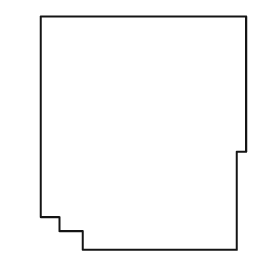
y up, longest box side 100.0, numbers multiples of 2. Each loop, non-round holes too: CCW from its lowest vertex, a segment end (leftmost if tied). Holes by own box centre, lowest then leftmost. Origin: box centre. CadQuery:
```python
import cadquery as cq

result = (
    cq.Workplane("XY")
    .moveTo(-26.0, -50.0)
    .lineTo(40.0, -50.0)
    .lineTo(40.0, -8.0)
    .lineTo(44.0, -8.0)
    .lineTo(44.0, 50.0)
    .lineTo(-44.0, 50.0)
    .lineTo(-44.0, -36.0)
    .lineTo(-36.0, -36.0)
    .lineTo(-36.0, -42.0)
    .lineTo(-26.0, -42.0)
    .close()
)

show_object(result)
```